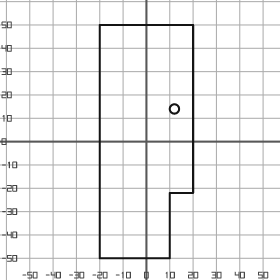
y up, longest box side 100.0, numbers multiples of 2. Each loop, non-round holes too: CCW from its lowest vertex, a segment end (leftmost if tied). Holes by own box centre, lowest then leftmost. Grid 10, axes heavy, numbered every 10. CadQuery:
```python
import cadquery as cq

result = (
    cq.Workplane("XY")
    .moveTo(-20.0, -50.0)
    .lineTo(10.0, -50.0)
    .lineTo(10.0, -22.0)
    .lineTo(20.0, -22.0)
    .lineTo(20.0, 50.0)
    .lineTo(-20.0, 50.0)
    .close()
    .moveTo(12.0, 14.0)
    .circle(2.0)
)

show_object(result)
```